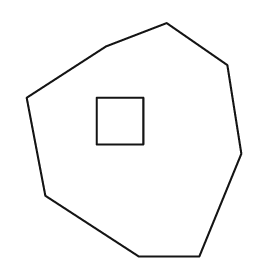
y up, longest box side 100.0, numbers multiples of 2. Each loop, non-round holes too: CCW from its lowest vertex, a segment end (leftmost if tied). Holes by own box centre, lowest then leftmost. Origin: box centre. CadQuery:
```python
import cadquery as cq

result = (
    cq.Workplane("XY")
    .moveTo(2.0, -50.0)
    .lineTo(28.0, -50.0)
    .lineTo(46.0, -6.0)
    .lineTo(40.0, 32.0)
    .lineTo(14.0, 50.0)
    .lineTo(-12.0, 40.0)
    .lineTo(-46.0, 18.0)
    .lineTo(-38.0, -24.0)
    .close()
    .moveTo(-16.0, -2.0)
    .lineTo(4.0, -2.0)
    .lineTo(4.0, 18.0)
    .lineTo(-16.0, 18.0)
    .close()
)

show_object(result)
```